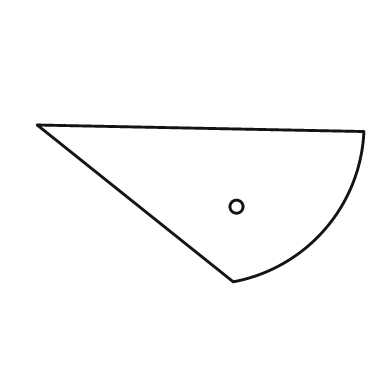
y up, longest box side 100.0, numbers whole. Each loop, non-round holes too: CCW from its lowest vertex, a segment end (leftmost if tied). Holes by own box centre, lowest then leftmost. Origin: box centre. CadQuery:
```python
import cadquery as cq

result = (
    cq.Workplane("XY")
    .moveTo(10.0, -24.0)
    .threePointArc((38.0, -8.0), (50.0, 22.0))
    .lineTo(-50.0, 24.0)
    .close()
    .moveTo(11.0, -1.0)
    .circle(2.0)
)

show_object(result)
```